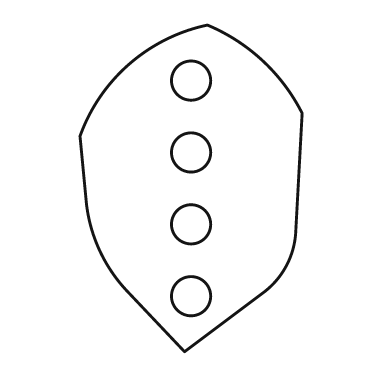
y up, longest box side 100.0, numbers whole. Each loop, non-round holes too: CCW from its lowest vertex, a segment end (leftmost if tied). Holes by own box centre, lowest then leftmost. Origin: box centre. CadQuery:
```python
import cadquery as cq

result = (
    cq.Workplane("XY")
    .moveTo(-2.0, -50.0)
    .lineTo(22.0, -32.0)
    .threePointArc((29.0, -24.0), (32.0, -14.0))
    .lineTo(34.0, 23.0)
    .threePointArc((22.0, 39.0), (5.0, 50.0))
    .threePointArc((-19.0, 38.0), (-34.0, 16.0))
    .lineTo(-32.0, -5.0)
    .threePointArc((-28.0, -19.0), (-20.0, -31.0))
    .close()
    .moveTo(0.0, -33.0)
    .circle(6.0)
    .moveTo(0.0, -11.0)
    .circle(6.0)
    .moveTo(0.0, 11.0)
    .circle(6.0)
    .moveTo(0.0, 33.0)
    .circle(6.0)
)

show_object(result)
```